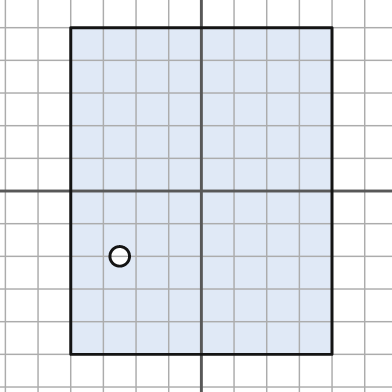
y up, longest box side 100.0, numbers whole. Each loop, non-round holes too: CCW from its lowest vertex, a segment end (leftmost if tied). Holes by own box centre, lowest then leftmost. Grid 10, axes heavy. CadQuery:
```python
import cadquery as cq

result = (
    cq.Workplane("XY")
    .moveTo(-40.0, -50.0)
    .lineTo(40.0, -50.0)
    .lineTo(40.0, 50.0)
    .lineTo(-40.0, 50.0)
    .close()
    .moveTo(-25.0, -20.0)
    .circle(3.0)
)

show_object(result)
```